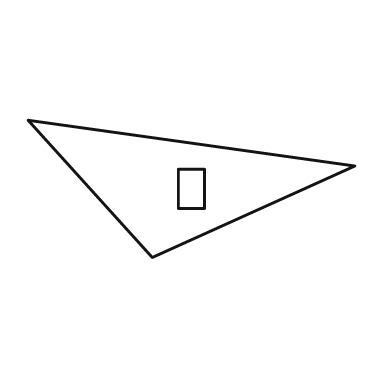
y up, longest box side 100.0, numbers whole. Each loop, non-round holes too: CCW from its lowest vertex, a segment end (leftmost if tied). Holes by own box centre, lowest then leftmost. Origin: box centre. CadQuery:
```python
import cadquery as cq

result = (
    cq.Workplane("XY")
    .moveTo(-12.0, -21.0)
    .lineTo(50.0, 7.0)
    .lineTo(-50.0, 21.0)
    .close()
    .moveTo(-4.0, -6.0)
    .lineTo(4.0, -6.0)
    .lineTo(4.0, 6.0)
    .lineTo(-4.0, 6.0)
    .close()
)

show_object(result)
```